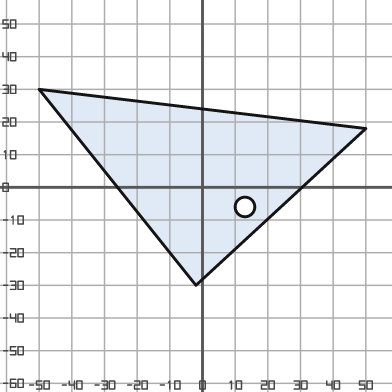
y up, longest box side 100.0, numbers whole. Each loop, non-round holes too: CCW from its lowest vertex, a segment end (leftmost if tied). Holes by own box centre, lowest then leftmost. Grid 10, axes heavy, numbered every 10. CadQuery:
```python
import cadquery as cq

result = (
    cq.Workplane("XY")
    .moveTo(-2.0, -30.0)
    .lineTo(50.0, 18.0)
    .lineTo(-50.0, 30.0)
    .close()
    .moveTo(13.0, -6.0)
    .circle(3.0)
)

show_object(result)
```